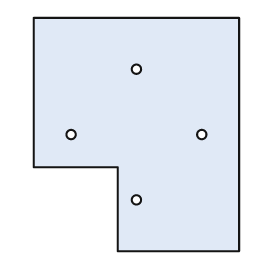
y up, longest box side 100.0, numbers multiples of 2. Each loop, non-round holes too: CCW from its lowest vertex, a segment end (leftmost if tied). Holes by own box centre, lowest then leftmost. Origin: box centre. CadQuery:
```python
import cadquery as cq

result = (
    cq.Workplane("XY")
    .moveTo(-8.0, -50.0)
    .lineTo(44.0, -50.0)
    .lineTo(44.0, 50.0)
    .lineTo(-44.0, 50.0)
    .lineTo(-44.0, -14.0)
    .lineTo(-8.0, -14.0)
    .close()
    .moveTo(0.0, -28.0)
    .circle(2.0)
    .moveTo(-28.0, 0.0)
    .circle(2.0)
    .moveTo(28.0, 0.0)
    .circle(2.0)
    .moveTo(0.0, 28.0)
    .circle(2.0)
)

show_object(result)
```